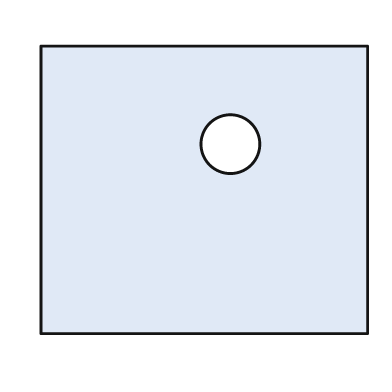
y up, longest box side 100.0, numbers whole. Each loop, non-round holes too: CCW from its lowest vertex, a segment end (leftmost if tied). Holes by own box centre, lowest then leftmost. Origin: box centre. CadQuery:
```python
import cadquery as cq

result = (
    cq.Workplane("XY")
    .moveTo(-50.0, -44.0)
    .lineTo(50.0, -44.0)
    .lineTo(50.0, 44.0)
    .lineTo(-50.0, 44.0)
    .close()
    .moveTo(8.0, 14.0)
    .circle(9.0)
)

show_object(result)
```